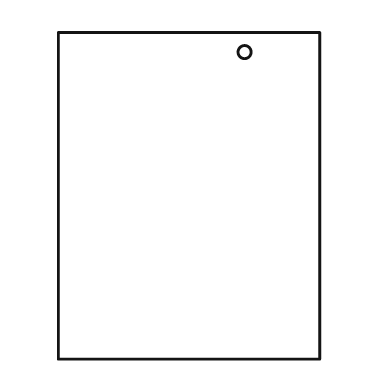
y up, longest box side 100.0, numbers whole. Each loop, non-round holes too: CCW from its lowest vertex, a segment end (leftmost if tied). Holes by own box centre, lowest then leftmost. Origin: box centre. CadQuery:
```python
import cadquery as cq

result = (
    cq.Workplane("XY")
    .moveTo(-40.0, -50.0)
    .lineTo(40.0, -50.0)
    .lineTo(40.0, 50.0)
    .lineTo(-40.0, 50.0)
    .close()
    .moveTo(17.0, 44.0)
    .circle(2.0)
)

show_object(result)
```